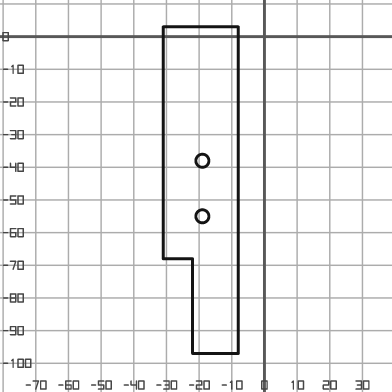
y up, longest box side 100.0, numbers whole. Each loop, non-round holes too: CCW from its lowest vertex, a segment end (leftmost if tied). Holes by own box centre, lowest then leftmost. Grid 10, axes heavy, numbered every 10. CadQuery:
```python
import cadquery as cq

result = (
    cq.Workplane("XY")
    .moveTo(-22.0, -97.0)
    .lineTo(-8.0, -97.0)
    .lineTo(-8.0, 3.0)
    .lineTo(-31.0, 3.0)
    .lineTo(-31.0, -68.0)
    .lineTo(-22.0, -68.0)
    .close()
    .moveTo(-19.0, -55.0)
    .circle(2.0)
    .moveTo(-19.0, -38.0)
    .circle(2.0)
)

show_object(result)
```